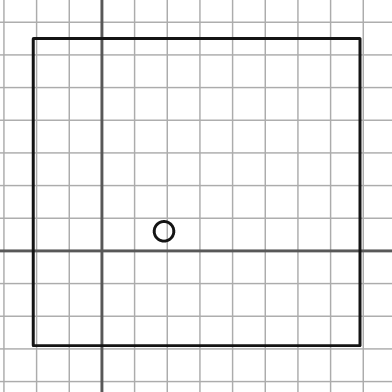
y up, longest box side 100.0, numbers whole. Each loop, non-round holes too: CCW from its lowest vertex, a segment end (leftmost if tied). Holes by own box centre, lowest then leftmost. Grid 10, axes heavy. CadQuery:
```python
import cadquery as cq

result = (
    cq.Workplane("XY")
    .moveTo(-21.0, -29.0)
    .lineTo(79.0, -29.0)
    .lineTo(79.0, 65.0)
    .lineTo(-21.0, 65.0)
    .close()
    .moveTo(19.0, 6.0)
    .circle(3.0)
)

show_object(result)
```